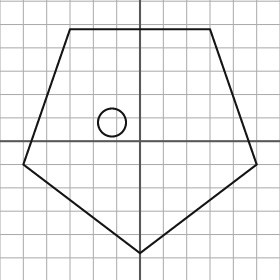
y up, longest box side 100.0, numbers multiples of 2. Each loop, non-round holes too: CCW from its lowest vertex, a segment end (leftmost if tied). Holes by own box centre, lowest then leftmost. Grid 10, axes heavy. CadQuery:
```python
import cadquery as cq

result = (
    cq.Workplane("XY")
    .moveTo(0.0, -48.0)
    .lineTo(50.0, -10.0)
    .lineTo(30.0, 48.0)
    .lineTo(-30.0, 48.0)
    .lineTo(-50.0, -10.0)
    .close()
    .moveTo(-12.0, 8.0)
    .circle(6.0)
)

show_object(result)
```